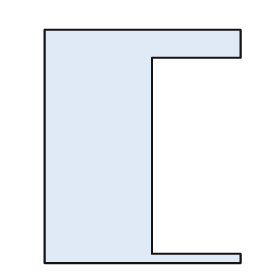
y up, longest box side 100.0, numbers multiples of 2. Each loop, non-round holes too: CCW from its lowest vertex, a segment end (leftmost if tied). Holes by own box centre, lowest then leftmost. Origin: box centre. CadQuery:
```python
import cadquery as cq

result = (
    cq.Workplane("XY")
    .moveTo(-42.0, -50.0)
    .lineTo(42.0, -50.0)
    .lineTo(42.0, -46.0)
    .lineTo(4.0, -46.0)
    .lineTo(4.0, 38.0)
    .lineTo(42.0, 38.0)
    .lineTo(42.0, 50.0)
    .lineTo(-42.0, 50.0)
    .close()
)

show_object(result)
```